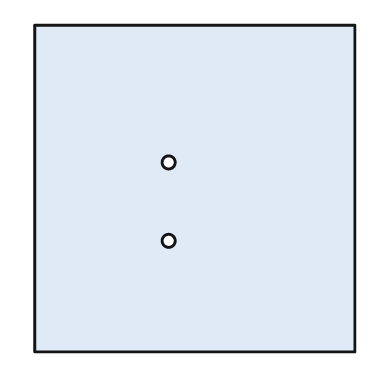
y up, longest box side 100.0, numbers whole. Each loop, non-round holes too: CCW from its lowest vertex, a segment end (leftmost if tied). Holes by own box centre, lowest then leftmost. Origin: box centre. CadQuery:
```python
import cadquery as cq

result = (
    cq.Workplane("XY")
    .moveTo(-49.0, -50.0)
    .lineTo(49.0, -50.0)
    .lineTo(49.0, 50.0)
    .lineTo(-49.0, 50.0)
    .close()
    .moveTo(-8.0, -16.0)
    .circle(2.0)
    .moveTo(-8.0, 8.0)
    .circle(2.0)
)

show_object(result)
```